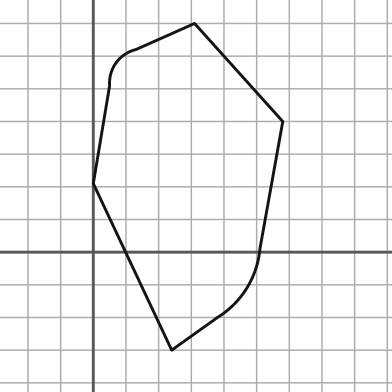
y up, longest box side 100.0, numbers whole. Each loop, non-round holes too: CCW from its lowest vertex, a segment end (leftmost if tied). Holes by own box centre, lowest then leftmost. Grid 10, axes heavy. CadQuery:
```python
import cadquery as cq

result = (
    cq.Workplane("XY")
    .moveTo(24.0, -30.0)
    .lineTo(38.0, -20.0)
    .threePointArc((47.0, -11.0), (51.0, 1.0))
    .lineTo(58.0, 40.0)
    .lineTo(31.0, 70.0)
    .lineTo(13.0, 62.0)
    .threePointArc((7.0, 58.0), (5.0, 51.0))
    .lineTo(0.0, 21.0)
    .close()
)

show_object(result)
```